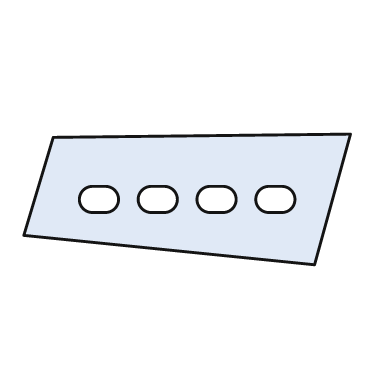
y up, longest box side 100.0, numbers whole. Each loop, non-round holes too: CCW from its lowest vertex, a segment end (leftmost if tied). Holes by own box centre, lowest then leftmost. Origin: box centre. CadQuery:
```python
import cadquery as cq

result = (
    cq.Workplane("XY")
    .moveTo(39.0, -20.0)
    .lineTo(50.0, 20.0)
    .lineTo(-41.0, 19.0)
    .lineTo(-50.0, -11.0)
    .close()
    .moveTo(-29.0, -4.0)
    .lineTo(-25.0, -4.0)
    .threePointArc((-21.0, 0.0), (-25.0, 4.0))
    .lineTo(-29.0, 4.0)
    .threePointArc((-33.0, 0.0), (-29.0, -4.0))
    .close()
    .moveTo(-11.0, -4.0)
    .lineTo(-7.0, -4.0)
    .threePointArc((-3.0, 0.0), (-7.0, 4.0))
    .lineTo(-11.0, 4.0)
    .threePointArc((-15.0, 0.0), (-11.0, -4.0))
    .close()
    .moveTo(7.0, -4.0)
    .lineTo(11.0, -4.0)
    .threePointArc((15.0, 0.0), (11.0, 4.0))
    .lineTo(7.0, 4.0)
    .threePointArc((3.0, 0.0), (7.0, -4.0))
    .close()
    .moveTo(25.0, -4.0)
    .lineTo(29.0, -4.0)
    .threePointArc((33.0, 0.0), (29.0, 4.0))
    .lineTo(25.0, 4.0)
    .threePointArc((21.0, 0.0), (25.0, -4.0))
    .close()
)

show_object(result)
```